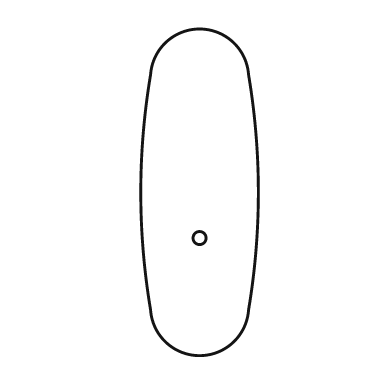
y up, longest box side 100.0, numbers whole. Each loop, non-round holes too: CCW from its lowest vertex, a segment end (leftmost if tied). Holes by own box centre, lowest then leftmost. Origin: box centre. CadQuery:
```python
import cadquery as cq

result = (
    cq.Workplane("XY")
    .moveTo(-15.0, -36.0)
    .threePointArc((0.0, -50.0), (15.0, -36.0))
    .threePointArc((18.0, 0.0), (15.0, 36.0))
    .threePointArc((0.0, 50.0), (-15.0, 36.0))
    .threePointArc((-18.0, 0.0), (-15.0, -36.0))
    .close()
    .moveTo(0.0, -14.0)
    .circle(2.0)
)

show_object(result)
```